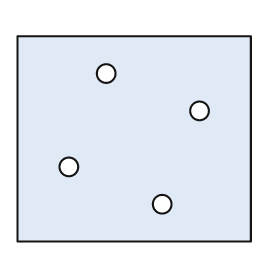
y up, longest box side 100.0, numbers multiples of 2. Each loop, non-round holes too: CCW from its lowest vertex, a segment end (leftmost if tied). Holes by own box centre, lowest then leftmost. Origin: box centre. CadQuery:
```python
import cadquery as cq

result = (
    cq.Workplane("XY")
    .moveTo(-50.0, -44.0)
    .lineTo(50.0, -44.0)
    .lineTo(50.0, 44.0)
    .lineTo(-50.0, 44.0)
    .close()
    .moveTo(12.0, -28.0)
    .circle(4.0)
    .moveTo(-28.0, -12.0)
    .circle(4.0)
    .moveTo(28.0, 12.0)
    .circle(4.0)
    .moveTo(-12.0, 28.0)
    .circle(4.0)
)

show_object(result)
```